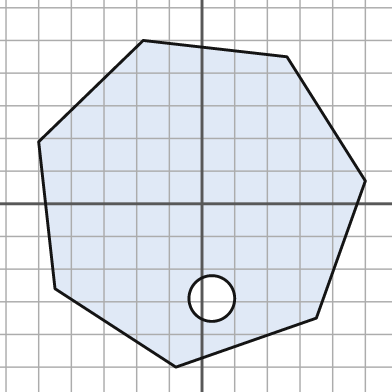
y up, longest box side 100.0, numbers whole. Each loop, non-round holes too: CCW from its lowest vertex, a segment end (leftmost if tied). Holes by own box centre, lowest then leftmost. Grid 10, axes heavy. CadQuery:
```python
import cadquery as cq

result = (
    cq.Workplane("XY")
    .moveTo(-8.0, -50.0)
    .lineTo(35.0, -35.0)
    .lineTo(50.0, 7.0)
    .lineTo(26.0, 45.0)
    .lineTo(-18.0, 50.0)
    .lineTo(-50.0, 19.0)
    .lineTo(-45.0, -26.0)
    .close()
    .moveTo(3.0, -29.0)
    .circle(7.0)
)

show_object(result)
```